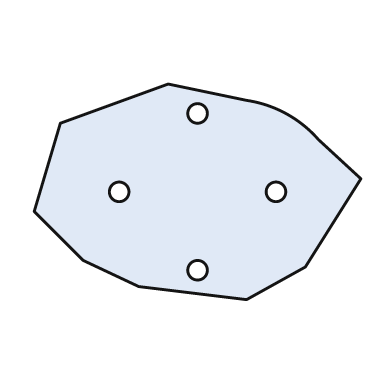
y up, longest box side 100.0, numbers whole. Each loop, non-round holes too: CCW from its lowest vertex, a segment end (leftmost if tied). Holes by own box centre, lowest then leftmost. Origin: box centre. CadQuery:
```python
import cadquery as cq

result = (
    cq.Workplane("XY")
    .moveTo(15.0, -33.0)
    .lineTo(33.0, -23.0)
    .lineTo(50.0, 4.0)
    .lineTo(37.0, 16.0)
    .threePointArc((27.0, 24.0), (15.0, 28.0))
    .lineTo(-9.0, 33.0)
    .lineTo(-42.0, 21.0)
    .lineTo(-50.0, -6.0)
    .lineTo(-35.0, -21.0)
    .lineTo(-18.0, -29.0)
    .close()
    .moveTo(0.0, -24.0)
    .circle(3.0)
    .moveTo(-24.0, 0.0)
    .circle(3.0)
    .moveTo(24.0, 0.0)
    .circle(3.0)
    .moveTo(0.0, 24.0)
    .circle(3.0)
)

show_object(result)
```